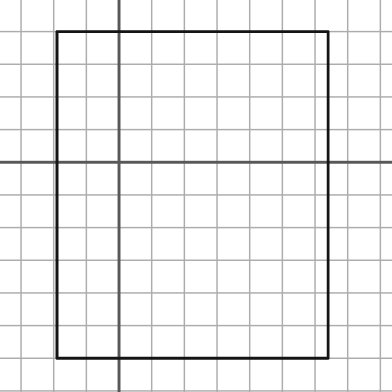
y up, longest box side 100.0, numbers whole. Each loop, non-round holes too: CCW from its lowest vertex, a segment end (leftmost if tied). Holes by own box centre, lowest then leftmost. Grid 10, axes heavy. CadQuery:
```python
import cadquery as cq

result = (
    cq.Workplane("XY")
    .moveTo(-19.0, -60.0)
    .lineTo(64.0, -60.0)
    .lineTo(64.0, 40.0)
    .lineTo(-19.0, 40.0)
    .close()
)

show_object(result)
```